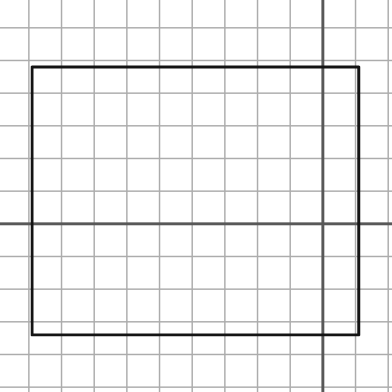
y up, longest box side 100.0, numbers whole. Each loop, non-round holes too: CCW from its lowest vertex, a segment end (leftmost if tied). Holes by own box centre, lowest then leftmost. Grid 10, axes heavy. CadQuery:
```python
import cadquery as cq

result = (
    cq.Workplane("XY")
    .moveTo(-89.0, -34.0)
    .lineTo(11.0, -34.0)
    .lineTo(11.0, 48.0)
    .lineTo(-89.0, 48.0)
    .close()
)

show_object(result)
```